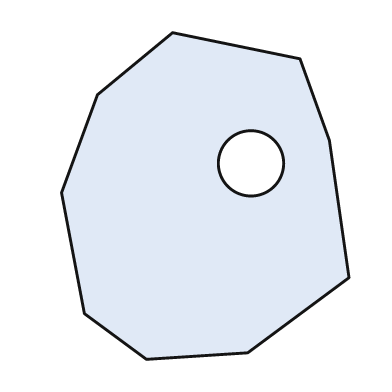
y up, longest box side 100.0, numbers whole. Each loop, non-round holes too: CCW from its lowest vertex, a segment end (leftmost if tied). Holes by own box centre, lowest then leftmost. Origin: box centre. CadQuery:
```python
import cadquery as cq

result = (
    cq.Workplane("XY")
    .moveTo(-18.0, -50.0)
    .lineTo(13.0, -48.0)
    .lineTo(44.0, -25.0)
    .lineTo(38.0, 17.0)
    .lineTo(29.0, 42.0)
    .lineTo(-10.0, 50.0)
    .lineTo(-33.0, 31.0)
    .lineTo(-44.0, 1.0)
    .lineTo(-37.0, -36.0)
    .close()
    .moveTo(14.0, 10.0)
    .circle(10.0)
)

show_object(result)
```